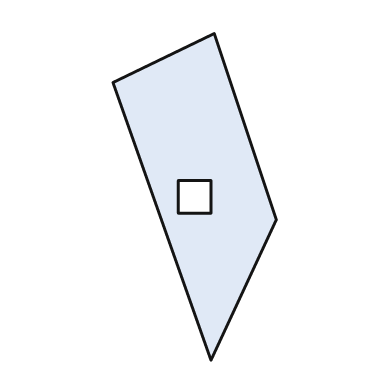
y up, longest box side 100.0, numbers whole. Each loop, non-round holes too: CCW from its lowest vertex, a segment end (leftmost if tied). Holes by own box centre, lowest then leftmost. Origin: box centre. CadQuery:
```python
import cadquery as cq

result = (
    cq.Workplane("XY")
    .moveTo(5.0, -50.0)
    .lineTo(25.0, -7.0)
    .lineTo(6.0, 50.0)
    .lineTo(-25.0, 35.0)
    .close()
    .moveTo(-5.0, -5.0)
    .lineTo(5.0, -5.0)
    .lineTo(5.0, 5.0)
    .lineTo(-5.0, 5.0)
    .close()
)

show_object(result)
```